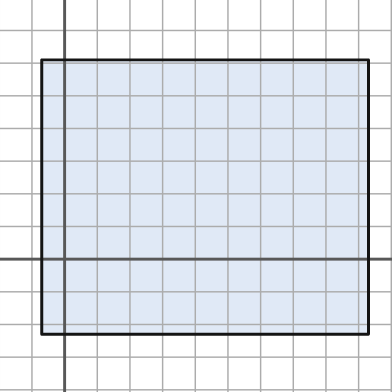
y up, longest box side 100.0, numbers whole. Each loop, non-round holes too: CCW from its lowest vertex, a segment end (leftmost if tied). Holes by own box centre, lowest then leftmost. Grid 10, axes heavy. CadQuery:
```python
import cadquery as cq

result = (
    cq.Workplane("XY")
    .moveTo(-7.0, -23.0)
    .lineTo(93.0, -23.0)
    .lineTo(93.0, 61.0)
    .lineTo(-7.0, 61.0)
    .close()
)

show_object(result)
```